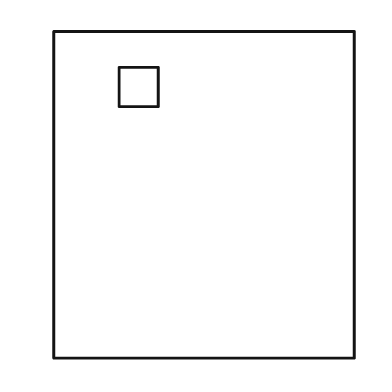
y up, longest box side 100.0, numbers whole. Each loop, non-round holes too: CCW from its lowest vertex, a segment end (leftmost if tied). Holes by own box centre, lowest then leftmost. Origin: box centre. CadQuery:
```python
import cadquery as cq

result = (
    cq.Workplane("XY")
    .moveTo(-46.0, -50.0)
    .lineTo(46.0, -50.0)
    .lineTo(46.0, 50.0)
    .lineTo(-46.0, 50.0)
    .close()
    .moveTo(-26.0, 27.0)
    .lineTo(-14.0, 27.0)
    .lineTo(-14.0, 39.0)
    .lineTo(-26.0, 39.0)
    .close()
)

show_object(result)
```